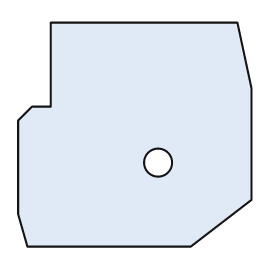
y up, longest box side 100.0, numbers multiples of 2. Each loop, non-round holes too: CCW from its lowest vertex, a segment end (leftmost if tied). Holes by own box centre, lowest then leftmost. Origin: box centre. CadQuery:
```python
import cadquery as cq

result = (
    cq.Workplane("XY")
    .moveTo(-46.0, -48.0)
    .lineTo(24.0, -48.0)
    .lineTo(50.0, -28.0)
    .lineTo(50.0, 20.0)
    .lineTo(44.0, 48.0)
    .lineTo(-36.0, 48.0)
    .lineTo(-36.0, 12.0)
    .lineTo(-44.0, 12.0)
    .lineTo(-50.0, 6.0)
    .lineTo(-50.0, -34.0)
    .close()
    .moveTo(10.0, -12.0)
    .circle(6.0)
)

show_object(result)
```